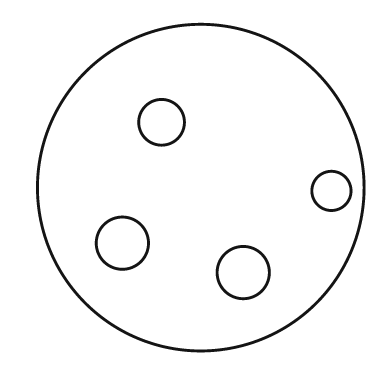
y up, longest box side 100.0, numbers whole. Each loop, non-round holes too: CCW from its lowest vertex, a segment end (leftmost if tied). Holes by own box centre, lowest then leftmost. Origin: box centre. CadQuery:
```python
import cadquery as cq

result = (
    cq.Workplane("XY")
    .moveTo(0.0, 0.0)
    .circle(50.0)
    .moveTo(13.0, -26.0)
    .circle(8.0)
    .moveTo(-24.0, -17.0)
    .circle(8.0)
    .moveTo(40.0, -1.0)
    .circle(6.0)
    .moveTo(-12.0, 20.0)
    .circle(7.0)
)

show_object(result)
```